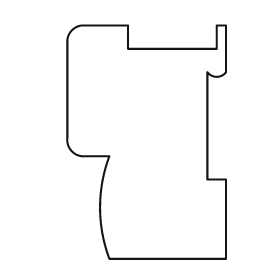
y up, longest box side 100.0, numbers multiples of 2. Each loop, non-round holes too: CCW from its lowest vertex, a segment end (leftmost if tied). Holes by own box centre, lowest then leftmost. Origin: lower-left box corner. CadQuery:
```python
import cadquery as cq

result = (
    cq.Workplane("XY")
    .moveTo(18.0, 0.0)
    .lineTo(68.0, 0.0)
    .lineTo(68.0, 34.0)
    .lineTo(60.0, 34.0)
    .lineTo(60.0, 80.0)
    .threePointArc((64.0, 78.0), (68.0, 80.0))
    .lineTo(68.0, 100.0)
    .lineTo(64.0, 100.0)
    .lineTo(64.0, 90.0)
    .lineTo(26.0, 90.0)
    .lineTo(26.0, 100.0)
    .lineTo(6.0, 100.0)
    .threePointArc((2.0, 98.0), (0.0, 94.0))
    .lineTo(0.0, 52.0)
    .threePointArc((2.0, 46.0), (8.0, 44.0))
    .lineTo(18.0, 44.0)
    .threePointArc((14.0, 22.0), (18.0, 0.0))
    .close()
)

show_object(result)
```